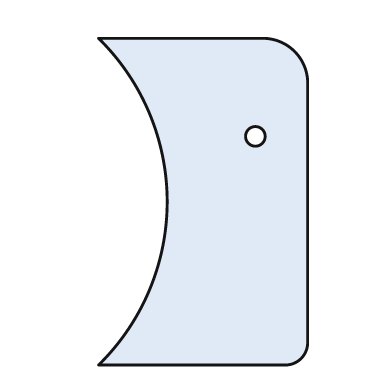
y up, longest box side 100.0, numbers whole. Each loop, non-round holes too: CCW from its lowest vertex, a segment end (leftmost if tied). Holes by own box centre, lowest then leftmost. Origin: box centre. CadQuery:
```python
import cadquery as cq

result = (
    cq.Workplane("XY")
    .moveTo(-32.0, -50.0)
    .lineTo(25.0, -50.0)
    .threePointArc((30.0, -48.0), (32.0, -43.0))
    .lineTo(32.0, 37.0)
    .threePointArc((28.0, 46.0), (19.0, 50.0))
    .lineTo(-32.0, 50.0)
    .threePointArc((-11.0, 0.0), (-32.0, -50.0))
    .close()
    .moveTo(16.0, 20.0)
    .circle(3.0)
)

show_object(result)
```